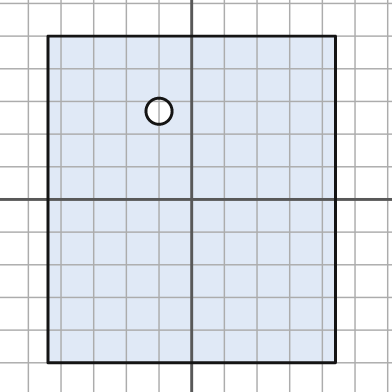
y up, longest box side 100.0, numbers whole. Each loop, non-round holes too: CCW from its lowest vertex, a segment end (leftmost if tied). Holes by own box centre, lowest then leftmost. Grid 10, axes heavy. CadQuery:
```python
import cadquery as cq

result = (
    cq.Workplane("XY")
    .moveTo(-44.0, -50.0)
    .lineTo(44.0, -50.0)
    .lineTo(44.0, 50.0)
    .lineTo(-44.0, 50.0)
    .close()
    .moveTo(-10.0, 27.0)
    .circle(4.0)
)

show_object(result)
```